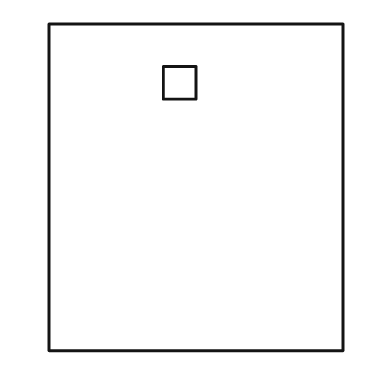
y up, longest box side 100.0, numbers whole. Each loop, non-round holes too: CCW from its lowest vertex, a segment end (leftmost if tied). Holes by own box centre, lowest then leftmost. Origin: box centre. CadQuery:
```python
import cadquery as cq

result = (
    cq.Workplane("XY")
    .moveTo(-45.0, -50.0)
    .lineTo(45.0, -50.0)
    .lineTo(45.0, 50.0)
    .lineTo(-45.0, 50.0)
    .close()
    .moveTo(-10.0, 27.0)
    .lineTo(0.0, 27.0)
    .lineTo(0.0, 37.0)
    .lineTo(-10.0, 37.0)
    .close()
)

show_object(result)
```